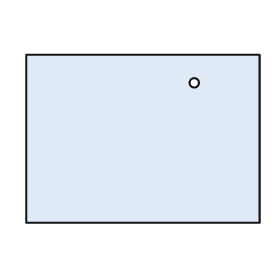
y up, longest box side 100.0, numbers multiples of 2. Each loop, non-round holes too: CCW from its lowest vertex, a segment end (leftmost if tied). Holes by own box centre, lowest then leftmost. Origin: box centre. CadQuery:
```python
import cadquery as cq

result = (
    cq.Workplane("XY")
    .moveTo(-50.0, -36.0)
    .lineTo(50.0, -36.0)
    .lineTo(50.0, 36.0)
    .lineTo(-50.0, 36.0)
    .close()
    .moveTo(22.0, 24.0)
    .circle(2.0)
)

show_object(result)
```